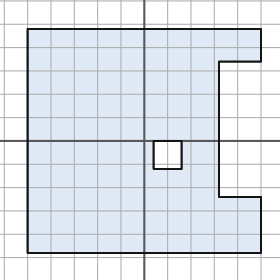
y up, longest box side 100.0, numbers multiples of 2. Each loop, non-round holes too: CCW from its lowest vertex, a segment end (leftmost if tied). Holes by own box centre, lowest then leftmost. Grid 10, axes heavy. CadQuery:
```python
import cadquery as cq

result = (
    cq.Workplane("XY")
    .moveTo(-50.0, -48.0)
    .lineTo(50.0, -48.0)
    .lineTo(50.0, -24.0)
    .lineTo(32.0, -24.0)
    .lineTo(32.0, 34.0)
    .lineTo(50.0, 34.0)
    .lineTo(50.0, 48.0)
    .lineTo(-50.0, 48.0)
    .close()
    .moveTo(4.0, -12.0)
    .lineTo(16.0, -12.0)
    .lineTo(16.0, 0.0)
    .lineTo(4.0, 0.0)
    .close()
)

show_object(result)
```